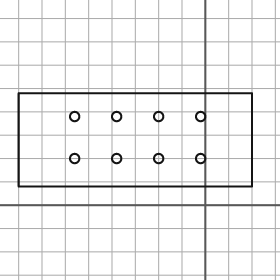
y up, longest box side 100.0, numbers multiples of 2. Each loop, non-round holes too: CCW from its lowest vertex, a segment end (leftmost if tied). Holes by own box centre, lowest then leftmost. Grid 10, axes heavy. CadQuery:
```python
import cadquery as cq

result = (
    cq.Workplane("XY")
    .moveTo(-80.0, 8.0)
    .lineTo(20.0, 8.0)
    .lineTo(20.0, 48.0)
    .lineTo(-80.0, 48.0)
    .close()
    .moveTo(-56.0, 20.0)
    .circle(2.0)
    .moveTo(-38.0, 20.0)
    .circle(2.0)
    .moveTo(-20.0, 20.0)
    .circle(2.0)
    .moveTo(-2.0, 20.0)
    .circle(2.0)
    .moveTo(-56.0, 38.0)
    .circle(2.0)
    .moveTo(-38.0, 38.0)
    .circle(2.0)
    .moveTo(-20.0, 38.0)
    .circle(2.0)
    .moveTo(-2.0, 38.0)
    .circle(2.0)
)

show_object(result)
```